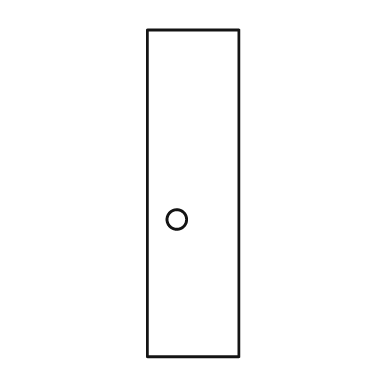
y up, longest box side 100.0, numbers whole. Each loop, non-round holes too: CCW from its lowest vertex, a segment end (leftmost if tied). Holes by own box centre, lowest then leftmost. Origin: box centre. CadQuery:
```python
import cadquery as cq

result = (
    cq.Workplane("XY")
    .moveTo(-14.0, -50.0)
    .lineTo(14.0, -50.0)
    .lineTo(14.0, 50.0)
    .lineTo(-14.0, 50.0)
    .close()
    .moveTo(-5.0, -8.0)
    .circle(3.0)
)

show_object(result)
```